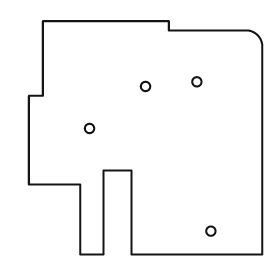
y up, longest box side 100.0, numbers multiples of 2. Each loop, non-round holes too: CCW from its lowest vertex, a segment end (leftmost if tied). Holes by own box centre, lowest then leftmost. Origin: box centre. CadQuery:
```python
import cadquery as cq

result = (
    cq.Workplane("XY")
    .moveTo(-28.0, -50.0)
    .lineTo(-18.0, -50.0)
    .lineTo(-18.0, -14.0)
    .lineTo(-6.0, -14.0)
    .lineTo(-6.0, -50.0)
    .lineTo(50.0, -50.0)
    .lineTo(50.0, 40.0)
    .threePointArc((48.0, 44.0), (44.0, 46.0))
    .lineTo(10.0, 46.0)
    .lineTo(10.0, 50.0)
    .lineTo(-44.0, 50.0)
    .lineTo(-44.0, 18.0)
    .lineTo(-50.0, 18.0)
    .lineTo(-50.0, -20.0)
    .lineTo(-28.0, -20.0)
    .close()
    .moveTo(28.0, -40.0)
    .circle(2.0)
    .moveTo(-24.0, 4.0)
    .circle(2.0)
    .moveTo(0.0, 22.0)
    .circle(2.0)
    .moveTo(22.0, 24.0)
    .circle(2.0)
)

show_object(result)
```